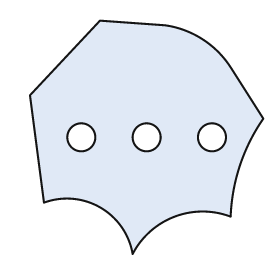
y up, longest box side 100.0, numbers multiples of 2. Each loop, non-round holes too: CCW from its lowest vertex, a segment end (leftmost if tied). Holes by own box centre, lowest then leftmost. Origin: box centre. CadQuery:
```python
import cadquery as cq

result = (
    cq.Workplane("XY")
    .moveTo(-6.0, -50.0)
    .threePointArc((12.0, -34.0), (36.0, -34.0))
    .threePointArc((40.0, -12.0), (50.0, 8.0))
    .lineTo(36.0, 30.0)
    .threePointArc((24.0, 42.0), (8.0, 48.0))
    .lineTo(-20.0, 50.0)
    .lineTo(-50.0, 18.0)
    .lineTo(-44.0, -28.0)
    .threePointArc((-20.0, -30.0), (-6.0, -50.0))
    .close()
    .moveTo(-28.0, 0.0)
    .circle(6.0)
    .moveTo(0.0, 0.0)
    .circle(6.0)
    .moveTo(28.0, 0.0)
    .circle(6.0)
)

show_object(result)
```